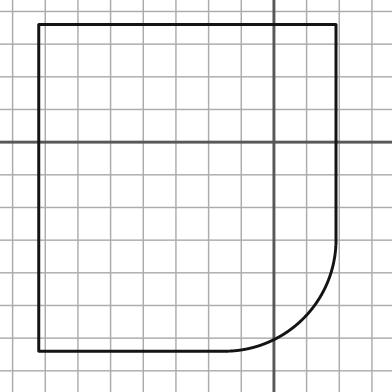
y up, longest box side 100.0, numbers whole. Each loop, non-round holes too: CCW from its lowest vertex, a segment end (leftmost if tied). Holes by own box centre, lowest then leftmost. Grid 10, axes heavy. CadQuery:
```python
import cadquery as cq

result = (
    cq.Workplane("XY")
    .moveTo(-72.0, -64.0)
    .lineTo(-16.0, -64.0)
    .threePointArc((9.0, -54.0), (19.0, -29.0))
    .lineTo(19.0, 36.0)
    .lineTo(-72.0, 36.0)
    .close()
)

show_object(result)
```